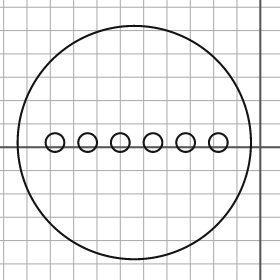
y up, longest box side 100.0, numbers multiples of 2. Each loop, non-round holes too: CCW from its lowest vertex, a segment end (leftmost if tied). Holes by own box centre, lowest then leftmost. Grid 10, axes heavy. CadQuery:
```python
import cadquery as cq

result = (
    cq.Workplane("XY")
    .moveTo(-54.0, 2.0)
    .circle(50.0)
    .moveTo(-88.0, 2.0)
    .circle(4.0)
    .moveTo(-74.0, 2.0)
    .circle(4.0)
    .moveTo(-60.0, 2.0)
    .circle(4.0)
    .moveTo(-46.0, 2.0)
    .circle(4.0)
    .moveTo(-32.0, 2.0)
    .circle(4.0)
    .moveTo(-18.0, 2.0)
    .circle(4.0)
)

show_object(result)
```